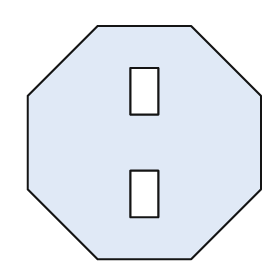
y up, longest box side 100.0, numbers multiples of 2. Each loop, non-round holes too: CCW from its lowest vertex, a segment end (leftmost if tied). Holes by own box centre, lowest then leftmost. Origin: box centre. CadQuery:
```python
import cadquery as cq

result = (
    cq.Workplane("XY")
    .moveTo(-20.0, -50.0)
    .lineTo(20.0, -50.0)
    .lineTo(50.0, -20.0)
    .lineTo(50.0, 20.0)
    .lineTo(20.0, 50.0)
    .lineTo(-20.0, 50.0)
    .lineTo(-50.0, 20.0)
    .lineTo(-50.0, -20.0)
    .close()
    .moveTo(-6.0, -32.0)
    .lineTo(6.0, -32.0)
    .lineTo(6.0, -12.0)
    .lineTo(-6.0, -12.0)
    .close()
    .moveTo(-6.0, 12.0)
    .lineTo(6.0, 12.0)
    .lineTo(6.0, 32.0)
    .lineTo(-6.0, 32.0)
    .close()
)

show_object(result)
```